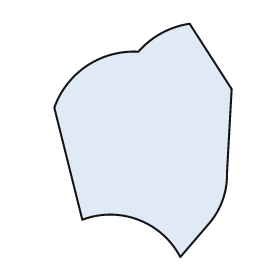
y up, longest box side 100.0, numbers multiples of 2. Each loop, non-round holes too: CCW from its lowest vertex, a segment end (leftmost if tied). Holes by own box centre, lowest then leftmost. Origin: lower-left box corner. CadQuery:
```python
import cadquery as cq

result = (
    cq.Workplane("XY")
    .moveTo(54.0, 0.0)
    .lineTo(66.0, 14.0)
    .threePointArc((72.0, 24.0), (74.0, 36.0))
    .lineTo(76.0, 72.0)
    .lineTo(58.0, 100.0)
    .threePointArc((46.0, 96.0), (36.0, 88.0))
    .threePointArc((14.0, 82.0), (0.0, 64.0))
    .lineTo(12.0, 16.0)
    .threePointArc((36.0, 16.0), (54.0, 0.0))
    .close()
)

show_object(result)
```